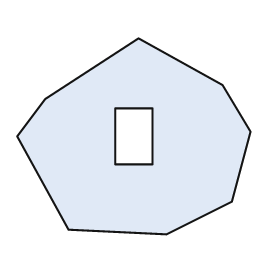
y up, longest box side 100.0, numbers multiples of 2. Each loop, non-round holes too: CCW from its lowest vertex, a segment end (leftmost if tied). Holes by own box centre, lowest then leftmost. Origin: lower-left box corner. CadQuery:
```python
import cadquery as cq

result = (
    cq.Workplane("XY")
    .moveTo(64.0, 0.0)
    .lineTo(92.0, 14.0)
    .lineTo(100.0, 44.0)
    .lineTo(88.0, 64.0)
    .lineTo(52.0, 84.0)
    .lineTo(12.0, 58.0)
    .lineTo(0.0, 42.0)
    .lineTo(22.0, 2.0)
    .close()
    .moveTo(42.0, 30.0)
    .lineTo(58.0, 30.0)
    .lineTo(58.0, 54.0)
    .lineTo(42.0, 54.0)
    .close()
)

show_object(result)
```